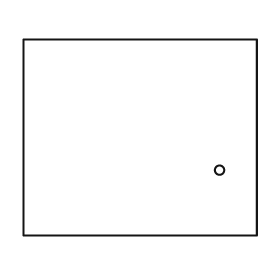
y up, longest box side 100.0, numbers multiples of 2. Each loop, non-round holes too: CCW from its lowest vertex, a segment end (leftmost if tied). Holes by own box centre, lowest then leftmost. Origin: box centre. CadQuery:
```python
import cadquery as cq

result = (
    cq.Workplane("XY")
    .moveTo(-50.0, -42.0)
    .lineTo(50.0, -42.0)
    .lineTo(50.0, 42.0)
    .lineTo(-50.0, 42.0)
    .close()
    .moveTo(34.0, -14.0)
    .circle(2.0)
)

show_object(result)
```